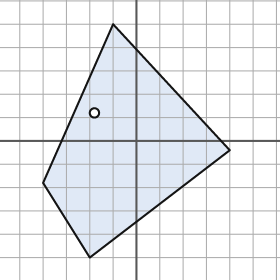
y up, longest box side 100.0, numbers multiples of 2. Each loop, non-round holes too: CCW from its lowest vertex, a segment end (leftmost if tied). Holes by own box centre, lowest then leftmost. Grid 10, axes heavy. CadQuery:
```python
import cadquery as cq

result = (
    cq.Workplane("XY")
    .moveTo(-20.0, -50.0)
    .lineTo(40.0, -4.0)
    .lineTo(-10.0, 50.0)
    .lineTo(-40.0, -18.0)
    .close()
    .moveTo(-18.0, 12.0)
    .circle(2.0)
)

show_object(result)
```